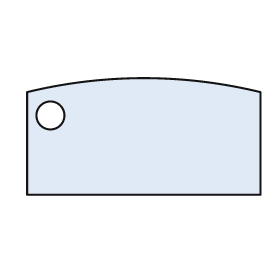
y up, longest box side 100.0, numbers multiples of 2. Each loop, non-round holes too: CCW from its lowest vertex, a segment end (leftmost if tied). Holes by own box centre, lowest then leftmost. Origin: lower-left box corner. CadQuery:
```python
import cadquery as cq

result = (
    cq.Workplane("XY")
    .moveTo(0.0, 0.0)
    .lineTo(100.0, 0.0)
    .lineTo(100.0, 44.0)
    .threePointArc((50.0, 50.0), (0.0, 44.0))
    .close()
    .moveTo(10.0, 34.0)
    .circle(6.0)
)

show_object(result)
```